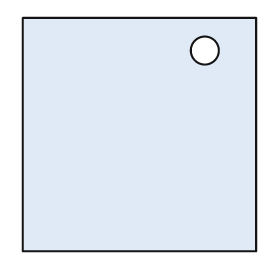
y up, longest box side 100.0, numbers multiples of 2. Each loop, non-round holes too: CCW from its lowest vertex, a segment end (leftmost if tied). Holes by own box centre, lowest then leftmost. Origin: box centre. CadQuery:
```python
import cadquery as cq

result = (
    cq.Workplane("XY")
    .moveTo(-50.0, -50.0)
    .lineTo(50.0, -50.0)
    .lineTo(50.0, 50.0)
    .lineTo(-50.0, 50.0)
    .close()
    .moveTo(28.0, 36.0)
    .circle(6.0)
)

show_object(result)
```